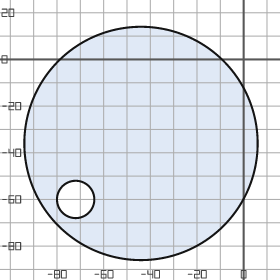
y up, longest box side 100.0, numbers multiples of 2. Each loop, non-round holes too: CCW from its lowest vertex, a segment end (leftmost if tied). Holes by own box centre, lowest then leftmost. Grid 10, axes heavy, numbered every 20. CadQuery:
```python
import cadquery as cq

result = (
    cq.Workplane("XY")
    .moveTo(-44.0, -36.0)
    .circle(50.0)
    .moveTo(-72.0, -60.0)
    .circle(8.0)
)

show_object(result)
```